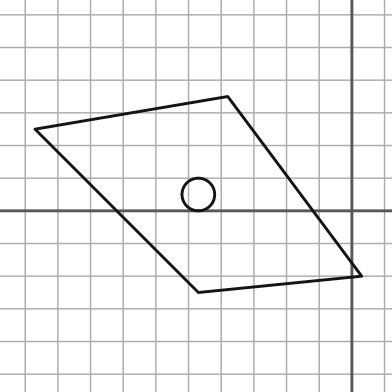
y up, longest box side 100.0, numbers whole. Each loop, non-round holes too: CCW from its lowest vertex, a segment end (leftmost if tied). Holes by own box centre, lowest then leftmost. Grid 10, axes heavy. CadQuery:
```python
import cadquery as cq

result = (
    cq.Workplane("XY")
    .moveTo(-47.0, -25.0)
    .lineTo(3.0, -20.0)
    .lineTo(-38.0, 35.0)
    .lineTo(-97.0, 25.0)
    .close()
    .moveTo(-47.0, 5.0)
    .circle(5.0)
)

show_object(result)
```